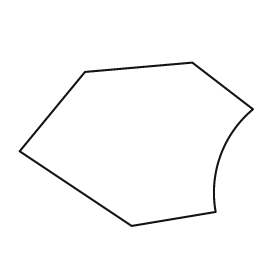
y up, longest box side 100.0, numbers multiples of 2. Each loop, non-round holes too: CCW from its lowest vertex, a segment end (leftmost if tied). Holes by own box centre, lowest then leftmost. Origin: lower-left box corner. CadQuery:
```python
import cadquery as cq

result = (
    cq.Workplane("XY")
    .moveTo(48.0, 0.0)
    .lineTo(84.0, 6.0)
    .threePointArc((86.0, 30.0), (100.0, 50.0))
    .lineTo(74.0, 70.0)
    .lineTo(28.0, 66.0)
    .lineTo(0.0, 32.0)
    .close()
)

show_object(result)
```